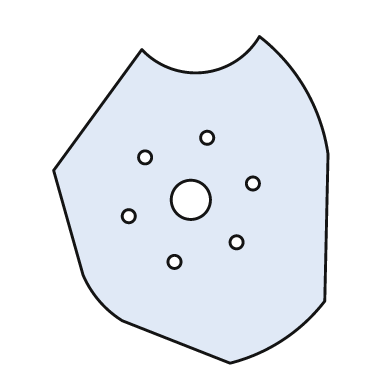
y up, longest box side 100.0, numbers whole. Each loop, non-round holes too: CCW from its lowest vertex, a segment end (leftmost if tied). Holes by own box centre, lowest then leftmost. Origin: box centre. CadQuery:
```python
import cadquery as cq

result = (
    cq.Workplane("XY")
    .moveTo(12.0, -50.0)
    .threePointArc((28.0, -43.0), (41.0, -31.0))
    .lineTo(42.0, 14.0)
    .threePointArc((35.0, 34.0), (21.0, 50.0))
    .threePointArc((4.0, 39.0), (-15.0, 46.0))
    .lineTo(-42.0, 9.0)
    .lineTo(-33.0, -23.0)
    .threePointArc((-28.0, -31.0), (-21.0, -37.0))
    .close()
    .moveTo(-5.0, -19.0)
    .circle(2.0)
    .moveTo(14.0, -13.0)
    .circle(2.0)
    .moveTo(-19.0, -5.0)
    .circle(2.0)
    .moveTo(0.0, 0.0)
    .circle(6.0)
    .moveTo(19.0, 5.0)
    .circle(2.0)
    .moveTo(-14.0, 13.0)
    .circle(2.0)
    .moveTo(5.0, 19.0)
    .circle(2.0)
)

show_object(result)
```